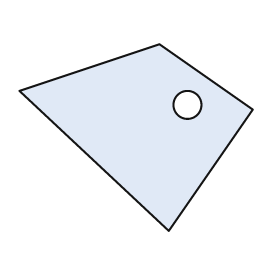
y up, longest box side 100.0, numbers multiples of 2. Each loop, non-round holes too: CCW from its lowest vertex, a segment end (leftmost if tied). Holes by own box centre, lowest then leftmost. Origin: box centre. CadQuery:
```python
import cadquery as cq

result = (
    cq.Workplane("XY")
    .moveTo(14.0, -40.0)
    .lineTo(50.0, 12.0)
    .lineTo(10.0, 40.0)
    .lineTo(-50.0, 20.0)
    .close()
    .moveTo(22.0, 14.0)
    .circle(6.0)
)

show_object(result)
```